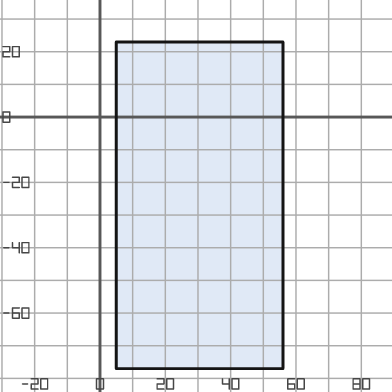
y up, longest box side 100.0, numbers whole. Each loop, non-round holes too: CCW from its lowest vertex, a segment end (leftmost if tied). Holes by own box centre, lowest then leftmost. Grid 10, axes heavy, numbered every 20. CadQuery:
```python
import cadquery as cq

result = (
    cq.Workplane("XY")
    .moveTo(5.0, -77.0)
    .lineTo(56.0, -77.0)
    .lineTo(56.0, 23.0)
    .lineTo(5.0, 23.0)
    .close()
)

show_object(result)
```